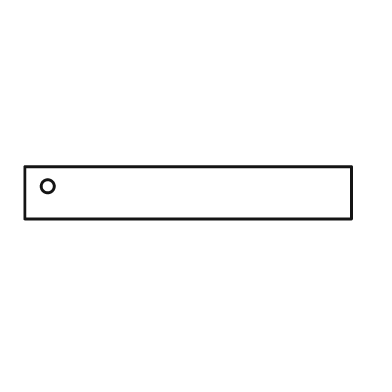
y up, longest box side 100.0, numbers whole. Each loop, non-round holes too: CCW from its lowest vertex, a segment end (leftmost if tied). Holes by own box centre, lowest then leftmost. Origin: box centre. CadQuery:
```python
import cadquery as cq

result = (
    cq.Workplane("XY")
    .moveTo(-50.0, -8.0)
    .lineTo(50.0, -8.0)
    .lineTo(50.0, 8.0)
    .lineTo(-50.0, 8.0)
    .close()
    .moveTo(-43.0, 2.0)
    .circle(2.0)
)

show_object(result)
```